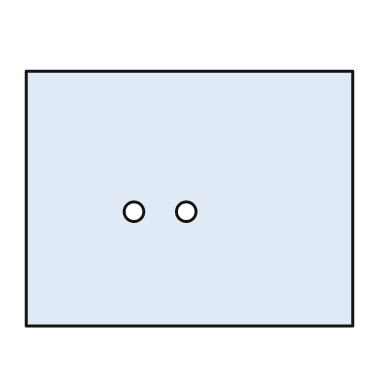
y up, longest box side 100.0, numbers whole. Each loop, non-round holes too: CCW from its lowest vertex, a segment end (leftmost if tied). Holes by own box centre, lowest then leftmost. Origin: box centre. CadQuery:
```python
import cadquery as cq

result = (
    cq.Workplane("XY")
    .moveTo(-50.0, -39.0)
    .lineTo(50.0, -39.0)
    .lineTo(50.0, 39.0)
    .lineTo(-50.0, 39.0)
    .close()
    .moveTo(-17.0, -4.0)
    .circle(3.0)
    .moveTo(-1.0, -4.0)
    .circle(3.0)
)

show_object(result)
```